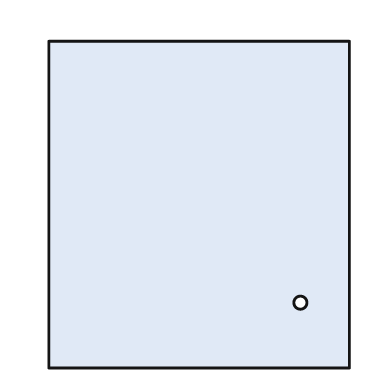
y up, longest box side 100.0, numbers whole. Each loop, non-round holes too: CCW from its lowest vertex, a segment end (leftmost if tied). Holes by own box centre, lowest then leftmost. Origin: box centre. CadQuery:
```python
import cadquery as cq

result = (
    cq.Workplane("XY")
    .moveTo(-46.0, -50.0)
    .lineTo(46.0, -50.0)
    .lineTo(46.0, 50.0)
    .lineTo(-46.0, 50.0)
    .close()
    .moveTo(31.0, -30.0)
    .circle(2.0)
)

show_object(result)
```